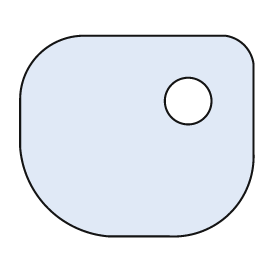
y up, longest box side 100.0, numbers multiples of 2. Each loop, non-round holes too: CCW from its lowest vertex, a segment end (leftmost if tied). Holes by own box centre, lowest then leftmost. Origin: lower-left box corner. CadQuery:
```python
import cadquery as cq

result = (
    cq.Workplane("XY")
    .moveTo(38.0, 0.0)
    .lineTo(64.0, 0.0)
    .threePointArc((90.0, 10.0), (100.0, 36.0))
    .lineTo(100.0, 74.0)
    .threePointArc((96.0, 82.0), (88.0, 86.0))
    .lineTo(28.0, 86.0)
    .threePointArc((8.0, 78.0), (0.0, 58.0))
    .lineTo(0.0, 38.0)
    .threePointArc((12.0, 12.0), (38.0, 0.0))
    .close()
    .moveTo(72.0, 58.0)
    .circle(10.0)
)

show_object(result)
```